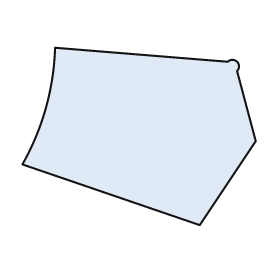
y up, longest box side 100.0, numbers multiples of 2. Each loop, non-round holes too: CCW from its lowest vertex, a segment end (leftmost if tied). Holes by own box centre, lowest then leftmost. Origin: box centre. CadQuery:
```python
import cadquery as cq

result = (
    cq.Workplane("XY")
    .moveTo(26.0, -38.0)
    .lineTo(50.0, -2.0)
    .lineTo(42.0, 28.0)
    .threePointArc((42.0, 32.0), (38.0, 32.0))
    .lineTo(-36.0, 38.0)
    .threePointArc((-40.0, 12.0), (-50.0, -12.0))
    .close()
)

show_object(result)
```